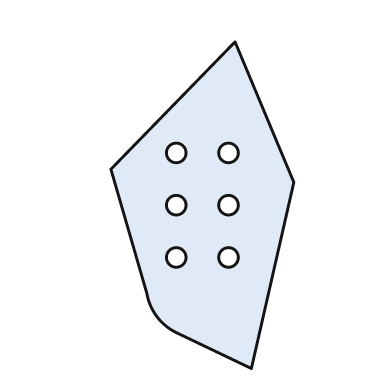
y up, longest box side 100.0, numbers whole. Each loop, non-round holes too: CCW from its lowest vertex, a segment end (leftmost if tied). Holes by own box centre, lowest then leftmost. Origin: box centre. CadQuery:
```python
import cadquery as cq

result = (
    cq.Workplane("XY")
    .moveTo(15.0, -50.0)
    .lineTo(28.0, 7.0)
    .lineTo(10.0, 50.0)
    .lineTo(-28.0, 11.0)
    .lineTo(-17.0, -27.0)
    .threePointArc((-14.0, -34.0), (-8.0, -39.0))
    .close()
    .moveTo(-8.0, -16.0)
    .circle(3.0)
    .moveTo(8.0, -16.0)
    .circle(3.0)
    .moveTo(-8.0, 0.0)
    .circle(3.0)
    .moveTo(8.0, 0.0)
    .circle(3.0)
    .moveTo(-8.0, 16.0)
    .circle(3.0)
    .moveTo(8.0, 16.0)
    .circle(3.0)
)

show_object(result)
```